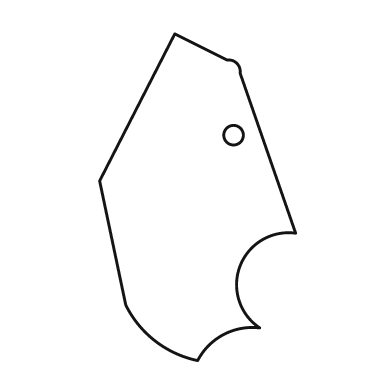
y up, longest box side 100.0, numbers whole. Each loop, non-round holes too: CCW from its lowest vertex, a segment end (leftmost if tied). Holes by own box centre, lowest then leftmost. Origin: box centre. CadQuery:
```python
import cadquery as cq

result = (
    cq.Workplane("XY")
    .moveTo(0.0, -50.0)
    .threePointArc((8.0, -42.0), (19.0, -40.0))
    .threePointArc((13.0, -21.0), (30.0, -11.0))
    .lineTo(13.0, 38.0)
    .threePointArc((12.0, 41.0), (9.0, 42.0))
    .lineTo(-7.0, 50.0)
    .lineTo(-30.0, 5.0)
    .lineTo(-22.0, -33.0)
    .threePointArc((-13.0, -44.0), (0.0, -50.0))
    .close()
    .moveTo(11.0, 19.0)
    .circle(3.0)
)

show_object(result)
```